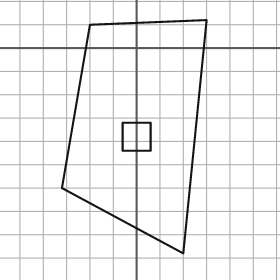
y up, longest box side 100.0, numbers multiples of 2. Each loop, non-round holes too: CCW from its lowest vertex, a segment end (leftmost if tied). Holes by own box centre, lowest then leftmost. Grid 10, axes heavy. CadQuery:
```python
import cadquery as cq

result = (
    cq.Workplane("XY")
    .moveTo(20.0, -88.0)
    .lineTo(30.0, 12.0)
    .lineTo(-20.0, 10.0)
    .lineTo(-32.0, -60.0)
    .close()
    .moveTo(-6.0, -44.0)
    .lineTo(6.0, -44.0)
    .lineTo(6.0, -32.0)
    .lineTo(-6.0, -32.0)
    .close()
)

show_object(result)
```